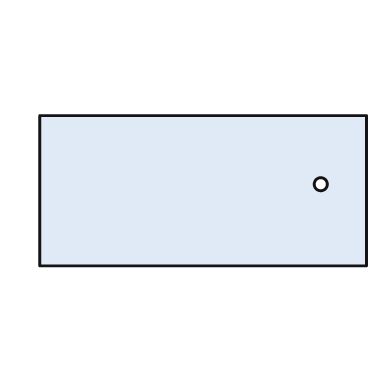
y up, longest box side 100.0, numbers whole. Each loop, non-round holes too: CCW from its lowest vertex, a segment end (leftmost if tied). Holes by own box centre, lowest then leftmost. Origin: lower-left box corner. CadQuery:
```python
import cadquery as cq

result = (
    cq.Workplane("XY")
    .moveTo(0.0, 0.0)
    .lineTo(100.0, 0.0)
    .lineTo(100.0, 46.0)
    .lineTo(0.0, 46.0)
    .close()
    .moveTo(86.0, 25.0)
    .circle(2.0)
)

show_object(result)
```